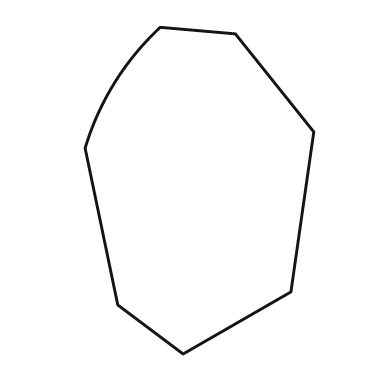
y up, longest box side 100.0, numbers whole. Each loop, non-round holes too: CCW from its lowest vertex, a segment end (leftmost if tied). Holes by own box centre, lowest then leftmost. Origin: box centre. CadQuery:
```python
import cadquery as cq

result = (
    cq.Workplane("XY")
    .moveTo(-5.0, -50.0)
    .lineTo(28.0, -31.0)
    .lineTo(35.0, 18.0)
    .lineTo(11.0, 48.0)
    .lineTo(-12.0, 50.0)
    .threePointArc((-26.0, 33.0), (-35.0, 13.0))
    .lineTo(-25.0, -35.0)
    .close()
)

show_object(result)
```